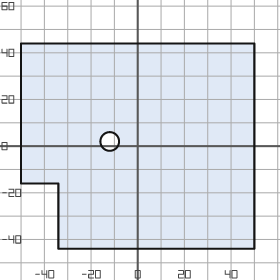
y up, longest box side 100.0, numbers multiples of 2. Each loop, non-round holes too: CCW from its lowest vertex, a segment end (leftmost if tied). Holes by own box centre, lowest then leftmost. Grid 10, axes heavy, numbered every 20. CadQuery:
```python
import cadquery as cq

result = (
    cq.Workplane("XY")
    .moveTo(-34.0, -44.0)
    .lineTo(50.0, -44.0)
    .lineTo(50.0, 44.0)
    .lineTo(-50.0, 44.0)
    .lineTo(-50.0, -16.0)
    .lineTo(-34.0, -16.0)
    .close()
    .moveTo(-12.0, 2.0)
    .circle(4.0)
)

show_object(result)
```